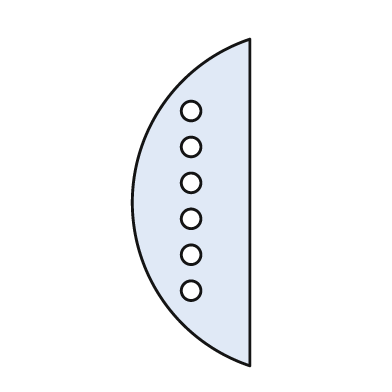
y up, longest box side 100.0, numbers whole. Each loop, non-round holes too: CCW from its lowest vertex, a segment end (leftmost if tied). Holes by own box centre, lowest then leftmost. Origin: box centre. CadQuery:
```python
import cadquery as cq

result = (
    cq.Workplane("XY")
    .moveTo(18.0, -50.0)
    .lineTo(18.0, 50.0)
    .threePointArc((-18.0, 0.0), (18.0, -50.0))
    .close()
    .moveTo(0.0, -27.0)
    .circle(3.0)
    .moveTo(0.0, -16.0)
    .circle(3.0)
    .moveTo(0.0, -5.0)
    .circle(3.0)
    .moveTo(0.0, 6.0)
    .circle(3.0)
    .moveTo(0.0, 17.0)
    .circle(3.0)
    .moveTo(0.0, 28.0)
    .circle(3.0)
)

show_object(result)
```